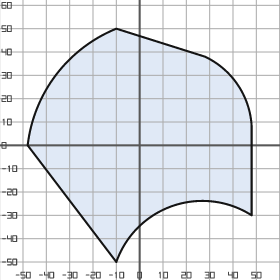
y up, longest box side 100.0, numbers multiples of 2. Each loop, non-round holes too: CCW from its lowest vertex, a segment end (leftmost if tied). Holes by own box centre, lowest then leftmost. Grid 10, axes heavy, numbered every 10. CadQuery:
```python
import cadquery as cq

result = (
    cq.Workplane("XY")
    .moveTo(-10.0, -50.0)
    .threePointArc((14.0, -26.0), (48.0, -30.0))
    .lineTo(48.0, 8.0)
    .threePointArc((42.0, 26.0), (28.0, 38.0))
    .lineTo(-10.0, 50.0)
    .threePointArc((-36.0, 30.0), (-48.0, 0.0))
    .close()
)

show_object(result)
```